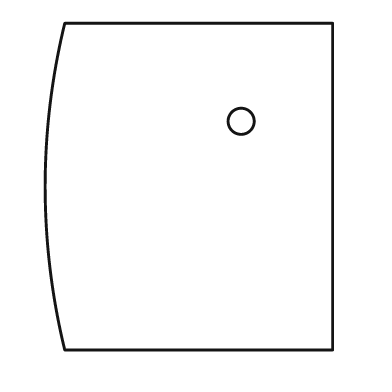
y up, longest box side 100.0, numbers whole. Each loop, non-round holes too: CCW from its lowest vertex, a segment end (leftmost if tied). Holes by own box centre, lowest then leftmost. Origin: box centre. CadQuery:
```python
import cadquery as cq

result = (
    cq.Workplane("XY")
    .moveTo(-38.0, -50.0)
    .lineTo(44.0, -50.0)
    .lineTo(44.0, 50.0)
    .lineTo(-38.0, 50.0)
    .threePointArc((-44.0, 0.0), (-38.0, -50.0))
    .close()
    .moveTo(16.0, 20.0)
    .circle(4.0)
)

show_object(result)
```